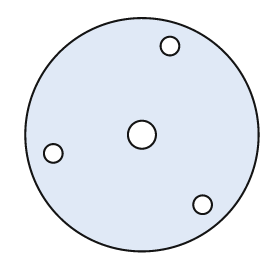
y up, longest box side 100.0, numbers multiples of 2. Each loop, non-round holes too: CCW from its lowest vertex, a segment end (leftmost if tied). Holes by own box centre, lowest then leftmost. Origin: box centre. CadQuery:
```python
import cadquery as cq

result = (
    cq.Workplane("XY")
    .moveTo(0.0, 0.0)
    .circle(50.0)
    .moveTo(26.0, -30.0)
    .circle(4.0)
    .moveTo(-38.0, -8.0)
    .circle(4.0)
    .moveTo(0.0, 0.0)
    .circle(6.0)
    .moveTo(12.0, 38.0)
    .circle(4.0)
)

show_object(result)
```